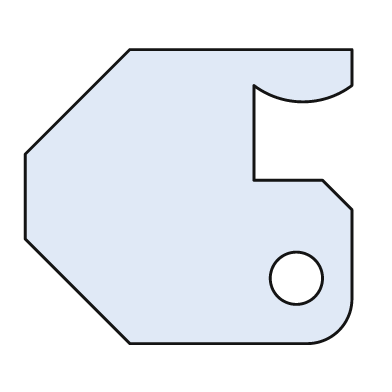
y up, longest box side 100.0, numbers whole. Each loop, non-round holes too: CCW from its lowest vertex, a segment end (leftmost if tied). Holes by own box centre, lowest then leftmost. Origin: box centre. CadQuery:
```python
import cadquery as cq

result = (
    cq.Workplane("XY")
    .moveTo(-18.0, -45.0)
    .lineTo(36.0, -45.0)
    .threePointArc((46.0, -41.0), (50.0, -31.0))
    .lineTo(50.0, -4.0)
    .lineTo(41.0, 5.0)
    .lineTo(20.0, 5.0)
    .lineTo(20.0, 34.0)
    .threePointArc((35.0, 29.0), (50.0, 34.0))
    .lineTo(50.0, 45.0)
    .lineTo(-18.0, 45.0)
    .lineTo(-50.0, 13.0)
    .lineTo(-50.0, -13.0)
    .close()
    .moveTo(33.0, -25.0)
    .circle(8.0)
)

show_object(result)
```